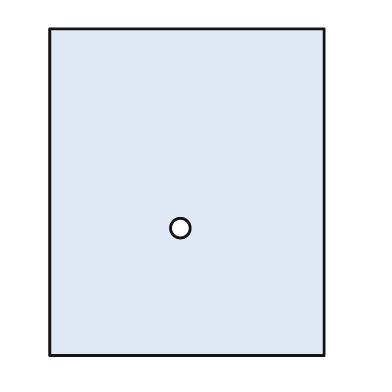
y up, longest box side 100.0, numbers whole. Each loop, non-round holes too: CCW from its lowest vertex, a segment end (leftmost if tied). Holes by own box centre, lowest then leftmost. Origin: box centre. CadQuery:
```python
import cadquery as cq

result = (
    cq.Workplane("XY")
    .moveTo(-42.0, -50.0)
    .lineTo(42.0, -50.0)
    .lineTo(42.0, 50.0)
    .lineTo(-42.0, 50.0)
    .close()
    .moveTo(-2.0, -11.0)
    .circle(3.0)
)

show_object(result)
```